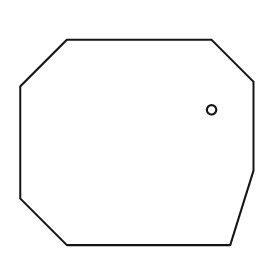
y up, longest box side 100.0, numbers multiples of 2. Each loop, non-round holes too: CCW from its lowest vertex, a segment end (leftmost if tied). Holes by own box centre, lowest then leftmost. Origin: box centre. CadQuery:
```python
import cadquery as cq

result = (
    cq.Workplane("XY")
    .moveTo(-30.0, -44.0)
    .lineTo(40.0, -44.0)
    .lineTo(50.0, -12.0)
    .lineTo(50.0, 26.0)
    .lineTo(32.0, 44.0)
    .lineTo(-30.0, 44.0)
    .lineTo(-50.0, 24.0)
    .lineTo(-50.0, -24.0)
    .close()
    .moveTo(32.0, 14.0)
    .circle(2.0)
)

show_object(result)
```